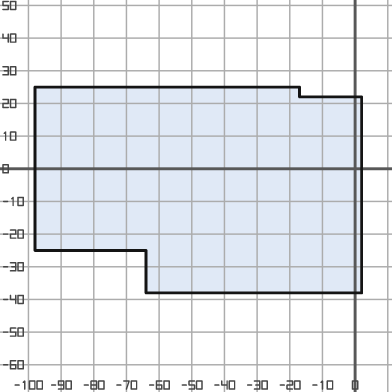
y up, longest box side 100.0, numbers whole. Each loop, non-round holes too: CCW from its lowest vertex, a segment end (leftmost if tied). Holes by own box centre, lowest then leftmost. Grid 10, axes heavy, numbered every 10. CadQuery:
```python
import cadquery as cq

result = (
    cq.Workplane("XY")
    .moveTo(-64.0, -38.0)
    .lineTo(2.0, -38.0)
    .lineTo(2.0, 22.0)
    .lineTo(-17.0, 22.0)
    .lineTo(-17.0, 25.0)
    .lineTo(-98.0, 25.0)
    .lineTo(-98.0, -25.0)
    .lineTo(-64.0, -25.0)
    .close()
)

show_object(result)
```